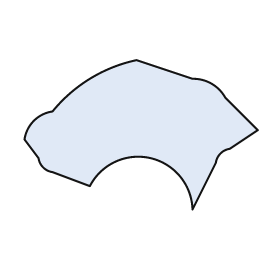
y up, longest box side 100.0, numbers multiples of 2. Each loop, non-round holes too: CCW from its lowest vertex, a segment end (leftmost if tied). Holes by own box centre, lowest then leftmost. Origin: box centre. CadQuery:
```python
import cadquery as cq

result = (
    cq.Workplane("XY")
    .moveTo(22.0, -32.0)
    .lineTo(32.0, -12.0)
    .threePointArc((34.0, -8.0), (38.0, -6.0))
    .lineTo(50.0, 2.0)
    .lineTo(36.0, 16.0)
    .threePointArc((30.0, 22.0), (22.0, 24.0))
    .lineTo(-2.0, 32.0)
    .threePointArc((-22.0, 24.0), (-38.0, 10.0))
    .threePointArc((-46.0, 6.0), (-50.0, -2.0))
    .lineTo(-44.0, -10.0)
    .threePointArc((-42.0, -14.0), (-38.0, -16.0))
    .lineTo(-22.0, -22.0)
    .threePointArc((4.0, -10.0), (22.0, -32.0))
    .close()
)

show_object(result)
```